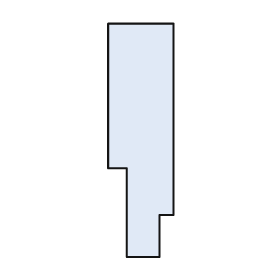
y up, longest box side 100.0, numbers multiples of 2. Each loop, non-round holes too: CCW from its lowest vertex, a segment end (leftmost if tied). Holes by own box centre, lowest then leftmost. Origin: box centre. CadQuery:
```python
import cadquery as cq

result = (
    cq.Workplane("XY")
    .moveTo(-6.0, -50.0)
    .lineTo(8.0, -50.0)
    .lineTo(8.0, -32.0)
    .lineTo(14.0, -32.0)
    .lineTo(14.0, 50.0)
    .lineTo(-14.0, 50.0)
    .lineTo(-14.0, -12.0)
    .lineTo(-6.0, -12.0)
    .close()
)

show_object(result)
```